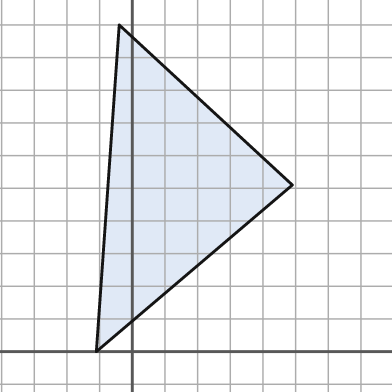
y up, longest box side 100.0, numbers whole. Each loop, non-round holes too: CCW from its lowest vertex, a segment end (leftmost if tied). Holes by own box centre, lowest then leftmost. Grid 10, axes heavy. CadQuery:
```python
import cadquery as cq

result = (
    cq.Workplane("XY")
    .moveTo(-11.0, 0.0)
    .lineTo(49.0, 51.0)
    .lineTo(-4.0, 100.0)
    .close()
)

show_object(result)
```